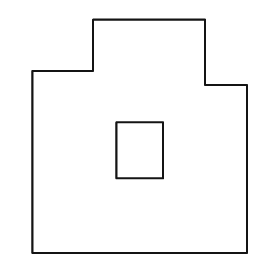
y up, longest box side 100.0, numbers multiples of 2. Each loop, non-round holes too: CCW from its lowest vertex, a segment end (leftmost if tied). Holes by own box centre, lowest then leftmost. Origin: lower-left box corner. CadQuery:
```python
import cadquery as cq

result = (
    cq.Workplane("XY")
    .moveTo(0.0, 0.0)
    .lineTo(92.0, 0.0)
    .lineTo(92.0, 72.0)
    .lineTo(74.0, 72.0)
    .lineTo(74.0, 100.0)
    .lineTo(26.0, 100.0)
    .lineTo(26.0, 78.0)
    .lineTo(0.0, 78.0)
    .close()
    .moveTo(36.0, 32.0)
    .lineTo(56.0, 32.0)
    .lineTo(56.0, 56.0)
    .lineTo(36.0, 56.0)
    .close()
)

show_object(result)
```